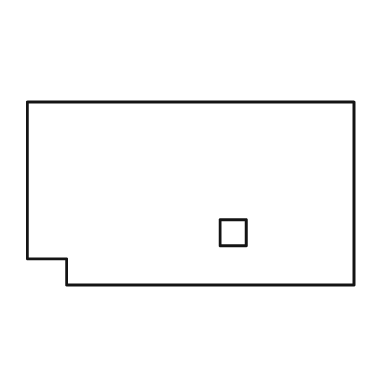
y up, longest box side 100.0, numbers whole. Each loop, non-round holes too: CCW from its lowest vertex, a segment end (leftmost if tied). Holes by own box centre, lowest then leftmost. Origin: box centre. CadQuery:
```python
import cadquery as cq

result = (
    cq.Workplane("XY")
    .moveTo(-38.0, -28.0)
    .lineTo(50.0, -28.0)
    .lineTo(50.0, 28.0)
    .lineTo(-50.0, 28.0)
    .lineTo(-50.0, -20.0)
    .lineTo(-38.0, -20.0)
    .close()
    .moveTo(9.0, -16.0)
    .lineTo(17.0, -16.0)
    .lineTo(17.0, -8.0)
    .lineTo(9.0, -8.0)
    .close()
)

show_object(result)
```